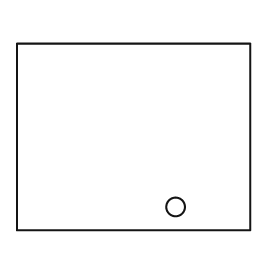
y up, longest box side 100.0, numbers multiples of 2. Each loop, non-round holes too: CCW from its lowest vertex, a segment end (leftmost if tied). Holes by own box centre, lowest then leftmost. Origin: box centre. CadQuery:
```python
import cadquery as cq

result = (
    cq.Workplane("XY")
    .moveTo(-50.0, -40.0)
    .lineTo(50.0, -40.0)
    .lineTo(50.0, 40.0)
    .lineTo(-50.0, 40.0)
    .close()
    .moveTo(18.0, -30.0)
    .circle(4.0)
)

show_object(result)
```